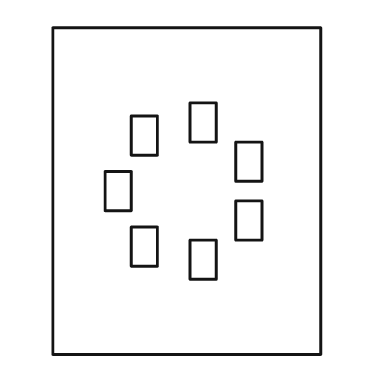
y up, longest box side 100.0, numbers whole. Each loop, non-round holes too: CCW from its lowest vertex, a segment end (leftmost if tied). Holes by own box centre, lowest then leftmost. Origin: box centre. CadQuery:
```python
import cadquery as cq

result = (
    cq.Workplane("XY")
    .moveTo(-41.0, -50.0)
    .lineTo(41.0, -50.0)
    .lineTo(41.0, 50.0)
    .lineTo(-41.0, 50.0)
    .close()
    .moveTo(1.0, -27.0)
    .lineTo(9.0, -27.0)
    .lineTo(9.0, -15.0)
    .lineTo(1.0, -15.0)
    .close()
    .moveTo(-17.0, -23.0)
    .lineTo(-9.0, -23.0)
    .lineTo(-9.0, -11.0)
    .lineTo(-17.0, -11.0)
    .close()
    .moveTo(15.0, -15.0)
    .lineTo(23.0, -15.0)
    .lineTo(23.0, -3.0)
    .lineTo(15.0, -3.0)
    .close()
    .moveTo(-25.0, -6.0)
    .lineTo(-17.0, -6.0)
    .lineTo(-17.0, 6.0)
    .lineTo(-25.0, 6.0)
    .close()
    .moveTo(15.0, 3.0)
    .lineTo(23.0, 3.0)
    .lineTo(23.0, 15.0)
    .lineTo(15.0, 15.0)
    .close()
    .moveTo(-17.0, 11.0)
    .lineTo(-9.0, 11.0)
    .lineTo(-9.0, 23.0)
    .lineTo(-17.0, 23.0)
    .close()
    .moveTo(1.0, 15.0)
    .lineTo(9.0, 15.0)
    .lineTo(9.0, 27.0)
    .lineTo(1.0, 27.0)
    .close()
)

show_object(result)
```